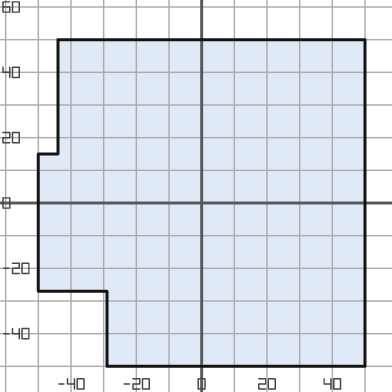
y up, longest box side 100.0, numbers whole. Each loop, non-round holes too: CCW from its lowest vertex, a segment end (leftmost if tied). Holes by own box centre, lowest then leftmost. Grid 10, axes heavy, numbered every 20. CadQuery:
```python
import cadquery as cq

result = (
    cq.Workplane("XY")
    .moveTo(-29.0, -50.0)
    .lineTo(50.0, -50.0)
    .lineTo(50.0, 50.0)
    .lineTo(-44.0, 50.0)
    .lineTo(-44.0, 15.0)
    .lineTo(-50.0, 15.0)
    .lineTo(-50.0, -27.0)
    .lineTo(-29.0, -27.0)
    .close()
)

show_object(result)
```